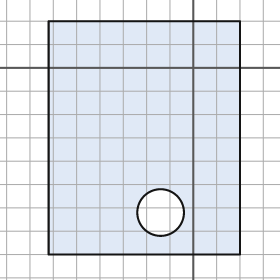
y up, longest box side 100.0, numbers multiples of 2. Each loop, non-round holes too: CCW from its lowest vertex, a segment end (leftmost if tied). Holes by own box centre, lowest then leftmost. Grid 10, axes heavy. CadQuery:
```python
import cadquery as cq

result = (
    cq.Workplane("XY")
    .moveTo(-62.0, -80.0)
    .lineTo(20.0, -80.0)
    .lineTo(20.0, 20.0)
    .lineTo(-62.0, 20.0)
    .close()
    .moveTo(-14.0, -62.0)
    .circle(10.0)
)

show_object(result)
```